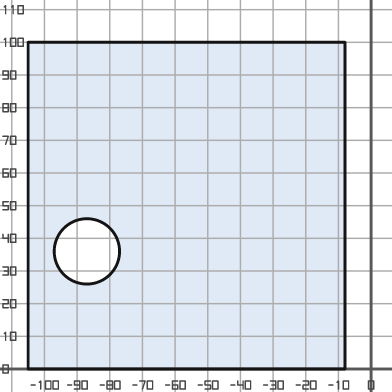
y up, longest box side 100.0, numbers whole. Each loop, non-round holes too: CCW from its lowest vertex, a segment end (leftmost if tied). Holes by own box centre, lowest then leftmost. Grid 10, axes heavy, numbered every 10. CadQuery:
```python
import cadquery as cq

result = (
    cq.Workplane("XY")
    .moveTo(-105.0, 0.0)
    .lineTo(-8.0, 0.0)
    .lineTo(-8.0, 100.0)
    .lineTo(-105.0, 100.0)
    .close()
    .moveTo(-87.0, 36.0)
    .circle(10.0)
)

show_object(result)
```